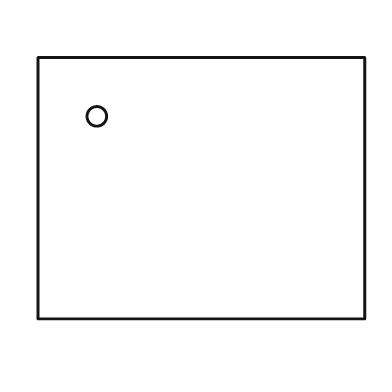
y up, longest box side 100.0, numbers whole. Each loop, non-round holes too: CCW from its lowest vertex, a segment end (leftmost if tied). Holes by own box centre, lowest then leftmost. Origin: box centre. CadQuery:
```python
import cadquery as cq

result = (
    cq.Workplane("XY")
    .moveTo(-50.0, -40.0)
    .lineTo(50.0, -40.0)
    .lineTo(50.0, 40.0)
    .lineTo(-50.0, 40.0)
    .close()
    .moveTo(-32.0, 22.0)
    .circle(3.0)
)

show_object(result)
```